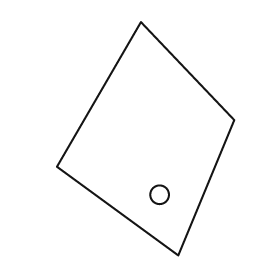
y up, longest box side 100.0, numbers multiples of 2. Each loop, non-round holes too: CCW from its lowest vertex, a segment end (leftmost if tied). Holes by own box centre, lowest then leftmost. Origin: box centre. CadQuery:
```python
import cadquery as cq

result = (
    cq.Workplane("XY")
    .moveTo(14.0, -50.0)
    .lineTo(38.0, 8.0)
    .lineTo(-2.0, 50.0)
    .lineTo(-38.0, -12.0)
    .close()
    .moveTo(6.0, -24.0)
    .circle(4.0)
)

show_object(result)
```